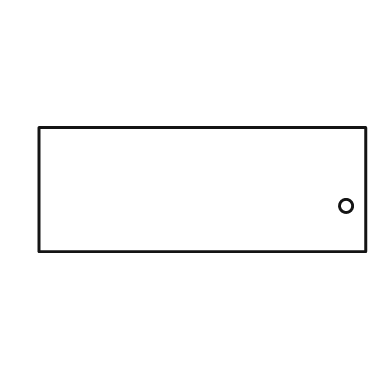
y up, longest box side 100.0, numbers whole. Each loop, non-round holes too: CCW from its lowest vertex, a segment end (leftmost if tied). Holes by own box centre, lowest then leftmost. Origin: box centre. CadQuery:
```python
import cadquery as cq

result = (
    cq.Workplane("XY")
    .moveTo(-50.0, -19.0)
    .lineTo(50.0, -19.0)
    .lineTo(50.0, 19.0)
    .lineTo(-50.0, 19.0)
    .close()
    .moveTo(44.0, -5.0)
    .circle(2.0)
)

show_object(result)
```